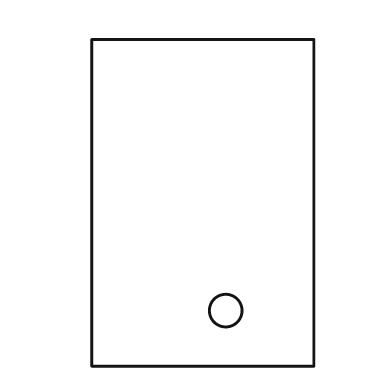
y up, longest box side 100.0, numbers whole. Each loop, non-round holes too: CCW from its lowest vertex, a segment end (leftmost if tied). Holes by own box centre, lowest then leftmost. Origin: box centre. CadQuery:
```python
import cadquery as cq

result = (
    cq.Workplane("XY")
    .moveTo(-34.0, -50.0)
    .lineTo(34.0, -50.0)
    .lineTo(34.0, 50.0)
    .lineTo(-34.0, 50.0)
    .close()
    .moveTo(7.0, -33.0)
    .circle(5.0)
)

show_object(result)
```